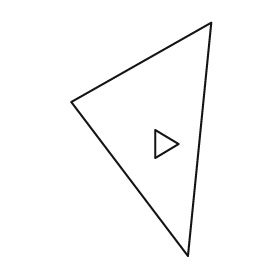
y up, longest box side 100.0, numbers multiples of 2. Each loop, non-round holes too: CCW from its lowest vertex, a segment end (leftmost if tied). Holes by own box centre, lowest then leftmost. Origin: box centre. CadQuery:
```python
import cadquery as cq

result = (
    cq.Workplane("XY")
    .moveTo(20.0, -50.0)
    .lineTo(30.0, 50.0)
    .lineTo(-30.0, 16.0)
    .close()
    .moveTo(6.0, -8.0)
    .lineTo(16.0, -2.0)
    .lineTo(6.0, 4.0)
    .close()
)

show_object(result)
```